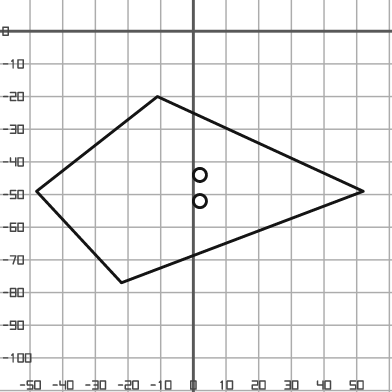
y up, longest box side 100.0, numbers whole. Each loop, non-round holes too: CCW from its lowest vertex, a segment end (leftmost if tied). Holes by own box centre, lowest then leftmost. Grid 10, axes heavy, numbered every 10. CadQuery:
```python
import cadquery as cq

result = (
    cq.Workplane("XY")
    .moveTo(-22.0, -77.0)
    .lineTo(52.0, -49.0)
    .lineTo(-11.0, -20.0)
    .lineTo(-48.0, -49.0)
    .close()
    .moveTo(2.0, -52.0)
    .circle(2.0)
    .moveTo(2.0, -44.0)
    .circle(2.0)
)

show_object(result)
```